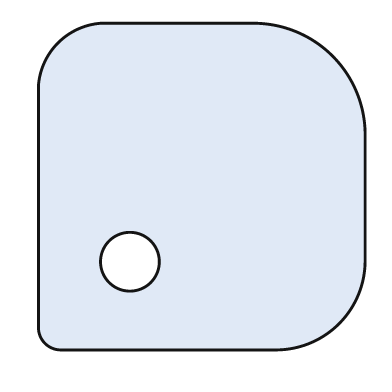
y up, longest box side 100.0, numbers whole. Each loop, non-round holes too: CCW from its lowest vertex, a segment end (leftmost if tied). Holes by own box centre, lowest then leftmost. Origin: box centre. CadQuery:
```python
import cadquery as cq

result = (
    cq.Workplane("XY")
    .moveTo(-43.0, -50.0)
    .lineTo(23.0, -50.0)
    .threePointArc((42.0, -42.0), (50.0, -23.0))
    .lineTo(50.0, 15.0)
    .threePointArc((40.0, 40.0), (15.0, 50.0))
    .lineTo(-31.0, 50.0)
    .threePointArc((-44.0, 44.0), (-50.0, 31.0))
    .lineTo(-50.0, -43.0)
    .threePointArc((-48.0, -48.0), (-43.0, -50.0))
    .close()
    .moveTo(-22.0, -23.0)
    .circle(9.0)
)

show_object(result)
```